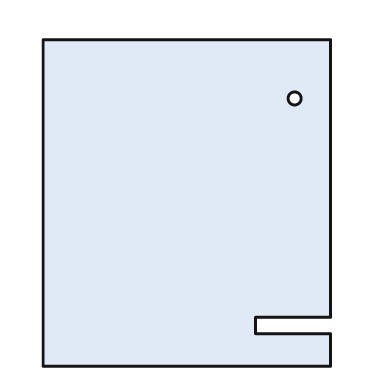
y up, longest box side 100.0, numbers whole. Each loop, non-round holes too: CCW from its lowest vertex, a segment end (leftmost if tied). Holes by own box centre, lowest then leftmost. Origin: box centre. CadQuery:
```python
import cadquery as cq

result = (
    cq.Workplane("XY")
    .moveTo(-44.0, -50.0)
    .lineTo(44.0, -50.0)
    .lineTo(44.0, -40.0)
    .lineTo(21.0, -40.0)
    .lineTo(21.0, -35.0)
    .lineTo(44.0, -35.0)
    .lineTo(44.0, 50.0)
    .lineTo(-44.0, 50.0)
    .close()
    .moveTo(33.0, 32.0)
    .circle(2.0)
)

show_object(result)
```